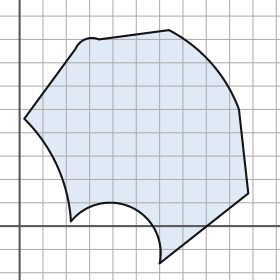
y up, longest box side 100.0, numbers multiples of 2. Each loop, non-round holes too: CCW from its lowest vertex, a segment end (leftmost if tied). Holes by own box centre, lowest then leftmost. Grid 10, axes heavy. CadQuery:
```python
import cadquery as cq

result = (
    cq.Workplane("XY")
    .moveTo(60.0, -16.0)
    .lineTo(98.0, 14.0)
    .lineTo(94.0, 50.0)
    .threePointArc((82.0, 70.0), (64.0, 84.0))
    .lineTo(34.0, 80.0)
    .threePointArc((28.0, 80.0), (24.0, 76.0))
    .lineTo(2.0, 46.0)
    .threePointArc((16.0, 26.0), (22.0, 2.0))
    .threePointArc((48.0, 8.0), (60.0, -16.0))
    .close()
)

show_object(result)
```